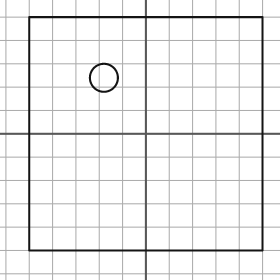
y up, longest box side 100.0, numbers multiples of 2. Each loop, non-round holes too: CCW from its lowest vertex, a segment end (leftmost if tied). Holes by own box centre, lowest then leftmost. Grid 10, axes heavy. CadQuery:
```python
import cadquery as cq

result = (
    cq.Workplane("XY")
    .moveTo(-50.0, -50.0)
    .lineTo(50.0, -50.0)
    .lineTo(50.0, 50.0)
    .lineTo(-50.0, 50.0)
    .close()
    .moveTo(-18.0, 24.0)
    .circle(6.0)
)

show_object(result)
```